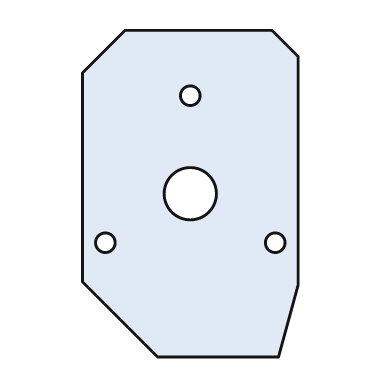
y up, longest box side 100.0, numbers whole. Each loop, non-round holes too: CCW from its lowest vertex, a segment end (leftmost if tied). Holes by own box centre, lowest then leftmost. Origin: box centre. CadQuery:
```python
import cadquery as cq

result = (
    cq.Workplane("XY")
    .moveTo(-10.0, -50.0)
    .lineTo(27.0, -50.0)
    .lineTo(33.0, -28.0)
    .lineTo(33.0, 42.0)
    .lineTo(25.0, 50.0)
    .lineTo(-20.0, 50.0)
    .lineTo(-33.0, 37.0)
    .lineTo(-33.0, -27.0)
    .close()
    .moveTo(-26.0, -15.0)
    .circle(3.0)
    .moveTo(26.0, -15.0)
    .circle(3.0)
    .moveTo(0.0, 0.0)
    .circle(8.0)
    .moveTo(0.0, 30.0)
    .circle(3.0)
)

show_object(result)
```